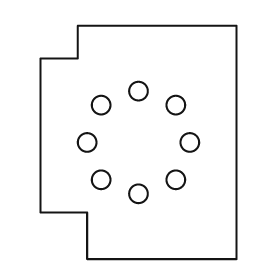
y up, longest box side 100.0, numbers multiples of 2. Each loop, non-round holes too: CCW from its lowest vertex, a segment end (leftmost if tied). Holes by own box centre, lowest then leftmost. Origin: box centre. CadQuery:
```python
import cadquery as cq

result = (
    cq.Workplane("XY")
    .moveTo(-22.0, -50.0)
    .lineTo(42.0, -50.0)
    .lineTo(42.0, 50.0)
    .lineTo(-26.0, 50.0)
    .lineTo(-26.0, 36.0)
    .lineTo(-42.0, 36.0)
    .lineTo(-42.0, -30.0)
    .lineTo(-22.0, -30.0)
    .close()
    .moveTo(0.0, -22.0)
    .circle(4.0)
    .moveTo(-16.0, -16.0)
    .circle(4.0)
    .moveTo(16.0, -16.0)
    .circle(4.0)
    .moveTo(-22.0, 0.0)
    .circle(4.0)
    .moveTo(22.0, 0.0)
    .circle(4.0)
    .moveTo(-16.0, 16.0)
    .circle(4.0)
    .moveTo(16.0, 16.0)
    .circle(4.0)
    .moveTo(0.0, 22.0)
    .circle(4.0)
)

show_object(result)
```